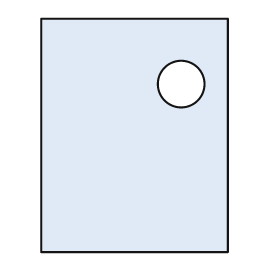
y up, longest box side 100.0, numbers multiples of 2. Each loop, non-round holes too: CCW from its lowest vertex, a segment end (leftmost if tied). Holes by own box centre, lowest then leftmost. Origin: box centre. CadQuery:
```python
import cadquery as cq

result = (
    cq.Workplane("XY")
    .moveTo(-40.0, -50.0)
    .lineTo(40.0, -50.0)
    .lineTo(40.0, 50.0)
    .lineTo(-40.0, 50.0)
    .close()
    .moveTo(20.0, 22.0)
    .circle(10.0)
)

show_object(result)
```